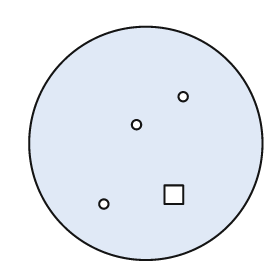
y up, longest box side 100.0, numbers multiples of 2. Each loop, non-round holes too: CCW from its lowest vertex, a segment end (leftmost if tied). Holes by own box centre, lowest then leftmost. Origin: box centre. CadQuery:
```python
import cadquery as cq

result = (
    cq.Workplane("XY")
    .moveTo(0.0, 0.0)
    .circle(50.0)
    .moveTo(-18.0, -26.0)
    .circle(2.0)
    .moveTo(8.0, -26.0)
    .lineTo(16.0, -26.0)
    .lineTo(16.0, -18.0)
    .lineTo(8.0, -18.0)
    .close()
    .moveTo(-4.0, 8.0)
    .circle(2.0)
    .moveTo(16.0, 20.0)
    .circle(2.0)
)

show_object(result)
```